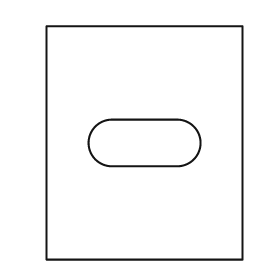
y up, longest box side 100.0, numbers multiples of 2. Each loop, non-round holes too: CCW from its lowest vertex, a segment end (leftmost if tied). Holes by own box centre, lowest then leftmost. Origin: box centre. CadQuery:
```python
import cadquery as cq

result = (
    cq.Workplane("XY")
    .moveTo(-42.0, -50.0)
    .lineTo(42.0, -50.0)
    .lineTo(42.0, 50.0)
    .lineTo(-42.0, 50.0)
    .close()
    .moveTo(-14.0, -10.0)
    .lineTo(14.0, -10.0)
    .threePointArc((24.0, 0.0), (14.0, 10.0))
    .lineTo(-14.0, 10.0)
    .threePointArc((-24.0, 0.0), (-14.0, -10.0))
    .close()
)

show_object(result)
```